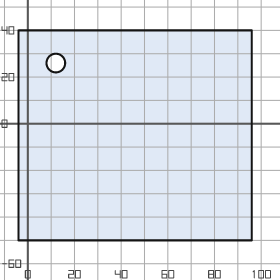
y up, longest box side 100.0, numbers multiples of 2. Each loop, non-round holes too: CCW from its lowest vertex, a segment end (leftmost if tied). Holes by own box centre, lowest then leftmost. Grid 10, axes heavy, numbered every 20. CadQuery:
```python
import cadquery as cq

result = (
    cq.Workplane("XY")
    .moveTo(-4.0, -50.0)
    .lineTo(96.0, -50.0)
    .lineTo(96.0, 40.0)
    .lineTo(-4.0, 40.0)
    .close()
    .moveTo(12.0, 26.0)
    .circle(4.0)
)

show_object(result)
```